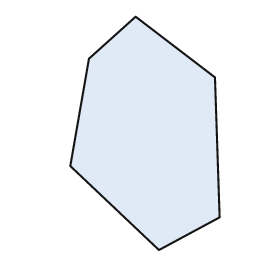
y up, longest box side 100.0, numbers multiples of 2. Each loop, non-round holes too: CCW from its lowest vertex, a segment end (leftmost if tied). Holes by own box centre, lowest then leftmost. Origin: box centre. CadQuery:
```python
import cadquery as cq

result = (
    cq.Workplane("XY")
    .moveTo(6.0, -50.0)
    .lineTo(32.0, -36.0)
    .lineTo(30.0, 24.0)
    .lineTo(-4.0, 50.0)
    .lineTo(-24.0, 32.0)
    .lineTo(-32.0, -14.0)
    .close()
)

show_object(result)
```